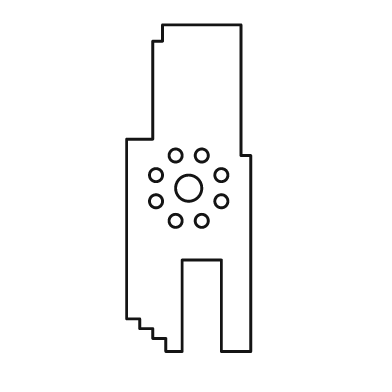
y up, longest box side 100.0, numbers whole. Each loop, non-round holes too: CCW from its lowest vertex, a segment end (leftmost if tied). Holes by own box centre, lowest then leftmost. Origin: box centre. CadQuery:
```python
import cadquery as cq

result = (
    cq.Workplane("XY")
    .moveTo(-7.0, -50.0)
    .lineTo(-2.0, -50.0)
    .lineTo(-2.0, -22.0)
    .lineTo(10.0, -22.0)
    .lineTo(10.0, -50.0)
    .lineTo(19.0, -50.0)
    .lineTo(19.0, 10.0)
    .lineTo(16.0, 10.0)
    .lineTo(16.0, 50.0)
    .lineTo(-8.0, 50.0)
    .lineTo(-8.0, 45.0)
    .lineTo(-11.0, 45.0)
    .lineTo(-11.0, 15.0)
    .lineTo(-19.0, 15.0)
    .lineTo(-19.0, -40.0)
    .lineTo(-15.0, -40.0)
    .lineTo(-15.0, -43.0)
    .lineTo(-11.0, -43.0)
    .lineTo(-11.0, -46.0)
    .lineTo(-7.0, -46.0)
    .close()
    .moveTo(-4.0, -10.0)
    .circle(2.0)
    .moveTo(4.0, -10.0)
    .circle(2.0)
    .moveTo(-10.0, -4.0)
    .circle(2.0)
    .moveTo(10.0, -4.0)
    .circle(2.0)
    .moveTo(0.0, 0.0)
    .circle(4.0)
    .moveTo(-10.0, 4.0)
    .circle(2.0)
    .moveTo(10.0, 4.0)
    .circle(2.0)
    .moveTo(-4.0, 10.0)
    .circle(2.0)
    .moveTo(4.0, 10.0)
    .circle(2.0)
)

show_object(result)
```